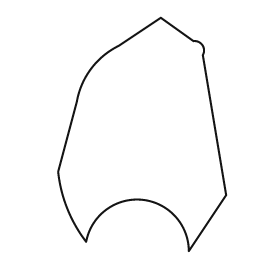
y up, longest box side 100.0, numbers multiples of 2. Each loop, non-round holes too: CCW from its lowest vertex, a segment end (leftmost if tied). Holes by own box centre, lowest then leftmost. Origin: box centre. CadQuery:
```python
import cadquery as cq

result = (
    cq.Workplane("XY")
    .moveTo(20.0, -50.0)
    .lineTo(36.0, -26.0)
    .lineTo(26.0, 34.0)
    .threePointArc((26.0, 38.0), (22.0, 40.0))
    .lineTo(8.0, 50.0)
    .lineTo(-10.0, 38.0)
    .threePointArc((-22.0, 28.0), (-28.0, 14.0))
    .lineTo(-36.0, -16.0)
    .threePointArc((-32.0, -32.0), (-24.0, -46.0))
    .threePointArc((0.0, -28.0), (20.0, -50.0))
    .close()
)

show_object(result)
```